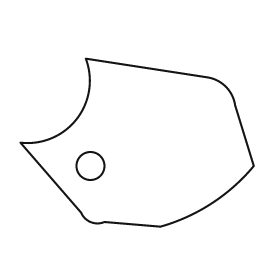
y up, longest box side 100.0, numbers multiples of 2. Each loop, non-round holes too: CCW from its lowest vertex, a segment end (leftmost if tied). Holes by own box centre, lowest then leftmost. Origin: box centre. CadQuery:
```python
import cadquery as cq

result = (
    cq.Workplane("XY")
    .moveTo(10.0, -36.0)
    .threePointArc((32.0, -26.0), (50.0, -10.0))
    .lineTo(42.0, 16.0)
    .threePointArc((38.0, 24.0), (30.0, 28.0))
    .lineTo(-22.0, 36.0)
    .threePointArc((-26.0, 10.0), (-50.0, 0.0))
    .lineTo(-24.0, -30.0)
    .threePointArc((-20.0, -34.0), (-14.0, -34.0))
    .close()
    .moveTo(-20.0, -10.0)
    .circle(6.0)
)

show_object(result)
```